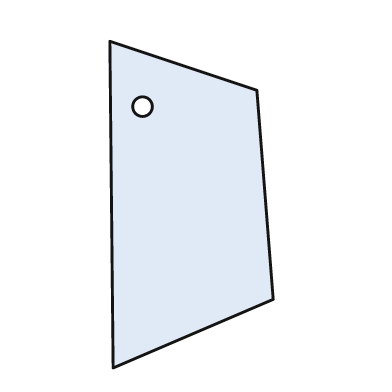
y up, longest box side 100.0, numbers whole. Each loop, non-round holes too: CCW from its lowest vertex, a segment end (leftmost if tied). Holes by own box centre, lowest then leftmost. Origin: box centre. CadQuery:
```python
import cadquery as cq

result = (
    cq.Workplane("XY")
    .moveTo(-24.0, -50.0)
    .lineTo(25.0, -29.0)
    .lineTo(20.0, 35.0)
    .lineTo(-25.0, 50.0)
    .close()
    .moveTo(-15.0, 30.0)
    .circle(3.0)
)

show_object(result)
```